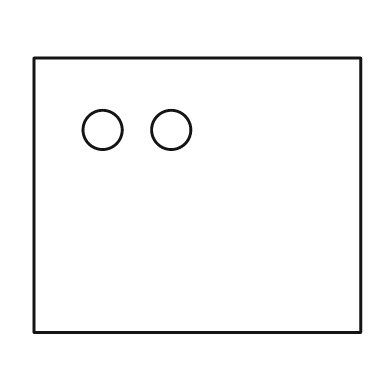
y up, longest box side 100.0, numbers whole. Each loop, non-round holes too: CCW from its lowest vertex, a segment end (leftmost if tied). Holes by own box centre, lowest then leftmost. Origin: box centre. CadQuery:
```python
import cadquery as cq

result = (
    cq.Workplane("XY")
    .moveTo(-50.0, -42.0)
    .lineTo(50.0, -42.0)
    .lineTo(50.0, 42.0)
    .lineTo(-50.0, 42.0)
    .close()
    .moveTo(-29.0, 20.0)
    .circle(6.0)
    .moveTo(-8.0, 20.0)
    .circle(6.0)
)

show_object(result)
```